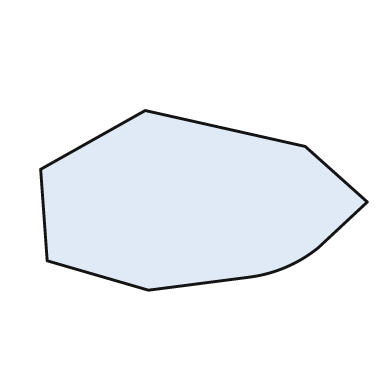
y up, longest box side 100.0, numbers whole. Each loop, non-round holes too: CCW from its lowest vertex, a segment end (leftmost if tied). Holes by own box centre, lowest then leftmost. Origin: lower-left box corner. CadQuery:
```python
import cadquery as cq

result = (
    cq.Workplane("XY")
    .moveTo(33.0, 0.0)
    .lineTo(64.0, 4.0)
    .threePointArc((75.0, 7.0), (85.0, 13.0))
    .lineTo(100.0, 27.0)
    .lineTo(81.0, 44.0)
    .lineTo(32.0, 55.0)
    .lineTo(0.0, 37.0)
    .lineTo(2.0, 9.0)
    .close()
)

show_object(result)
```